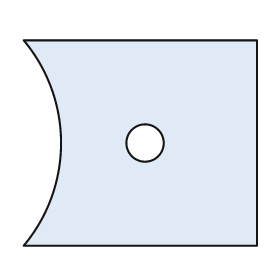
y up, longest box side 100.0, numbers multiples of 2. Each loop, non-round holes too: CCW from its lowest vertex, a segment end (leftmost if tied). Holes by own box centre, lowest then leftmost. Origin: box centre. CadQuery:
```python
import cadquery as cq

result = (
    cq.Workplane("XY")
    .moveTo(-50.0, -44.0)
    .lineTo(50.0, -44.0)
    .lineTo(50.0, 44.0)
    .lineTo(-50.0, 44.0)
    .threePointArc((-34.0, 0.0), (-50.0, -44.0))
    .close()
    .moveTo(2.0, 0.0)
    .circle(8.0)
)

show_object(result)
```